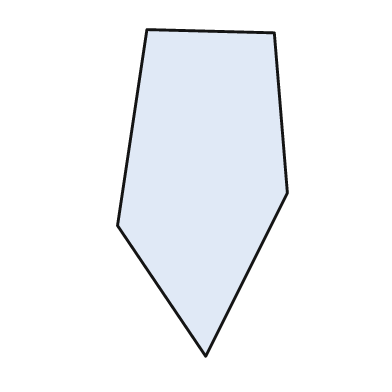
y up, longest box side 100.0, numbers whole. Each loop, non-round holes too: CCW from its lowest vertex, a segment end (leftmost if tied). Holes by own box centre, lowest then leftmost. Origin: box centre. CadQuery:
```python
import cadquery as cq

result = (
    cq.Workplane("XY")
    .moveTo(1.0, -50.0)
    .lineTo(26.0, 0.0)
    .lineTo(22.0, 49.0)
    .lineTo(-17.0, 50.0)
    .lineTo(-26.0, -10.0)
    .close()
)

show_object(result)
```